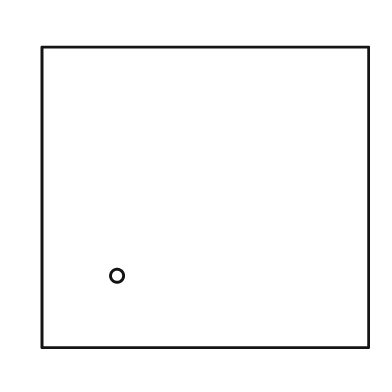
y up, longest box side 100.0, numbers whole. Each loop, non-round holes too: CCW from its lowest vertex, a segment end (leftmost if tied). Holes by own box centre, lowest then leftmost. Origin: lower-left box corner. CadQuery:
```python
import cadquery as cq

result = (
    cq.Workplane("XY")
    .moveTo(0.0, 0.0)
    .lineTo(100.0, 0.0)
    .lineTo(100.0, 92.0)
    .lineTo(0.0, 92.0)
    .close()
    .moveTo(23.0, 22.0)
    .circle(2.0)
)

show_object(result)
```